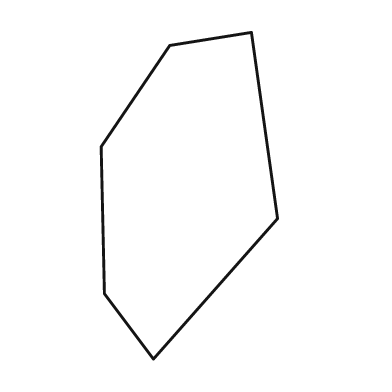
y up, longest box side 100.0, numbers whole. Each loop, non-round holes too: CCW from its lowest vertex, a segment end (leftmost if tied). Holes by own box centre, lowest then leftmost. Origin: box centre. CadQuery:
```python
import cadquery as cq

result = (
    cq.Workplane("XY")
    .moveTo(-11.0, -50.0)
    .lineTo(27.0, -7.0)
    .lineTo(19.0, 50.0)
    .lineTo(-6.0, 46.0)
    .lineTo(-27.0, 15.0)
    .lineTo(-26.0, -30.0)
    .close()
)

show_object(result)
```